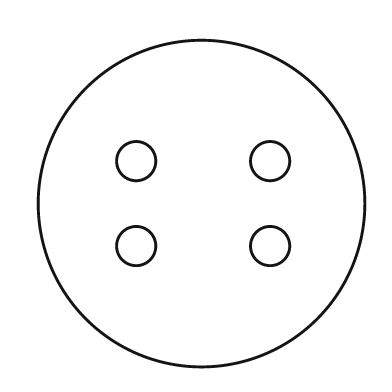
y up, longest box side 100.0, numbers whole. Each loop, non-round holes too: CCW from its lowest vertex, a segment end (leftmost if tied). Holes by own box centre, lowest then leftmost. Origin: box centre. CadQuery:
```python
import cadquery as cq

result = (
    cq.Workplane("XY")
    .moveTo(0.0, 0.0)
    .circle(50.0)
    .moveTo(-20.0, -13.0)
    .circle(6.0)
    .moveTo(21.0, -13.0)
    .circle(6.0)
    .moveTo(-20.0, 13.0)
    .circle(6.0)
    .moveTo(21.0, 13.0)
    .circle(6.0)
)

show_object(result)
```